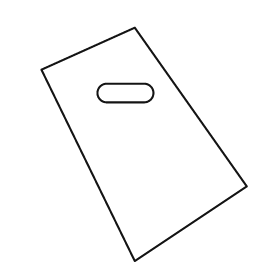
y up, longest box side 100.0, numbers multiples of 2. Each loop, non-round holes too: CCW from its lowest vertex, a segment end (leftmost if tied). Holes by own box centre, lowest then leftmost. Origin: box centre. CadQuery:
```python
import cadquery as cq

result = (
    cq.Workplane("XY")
    .moveTo(-4.0, -50.0)
    .lineTo(44.0, -18.0)
    .lineTo(-4.0, 50.0)
    .lineTo(-44.0, 32.0)
    .close()
    .moveTo(-16.0, 18.0)
    .lineTo(0.0, 18.0)
    .threePointArc((4.0, 22.0), (0.0, 26.0))
    .lineTo(-16.0, 26.0)
    .threePointArc((-20.0, 22.0), (-16.0, 18.0))
    .close()
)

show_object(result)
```